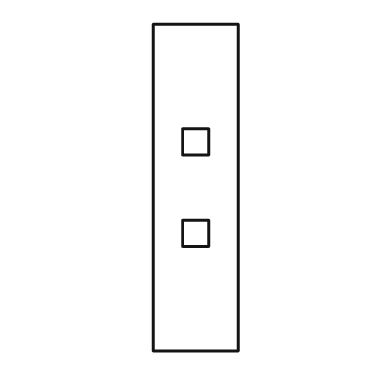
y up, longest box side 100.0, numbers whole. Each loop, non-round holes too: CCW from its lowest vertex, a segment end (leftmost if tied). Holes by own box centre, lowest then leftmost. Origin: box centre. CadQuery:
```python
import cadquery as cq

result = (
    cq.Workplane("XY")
    .moveTo(-13.0, -50.0)
    .lineTo(13.0, -50.0)
    .lineTo(13.0, 50.0)
    .lineTo(-13.0, 50.0)
    .close()
    .moveTo(-4.0, -18.0)
    .lineTo(4.0, -18.0)
    .lineTo(4.0, -10.0)
    .lineTo(-4.0, -10.0)
    .close()
    .moveTo(-4.0, 10.0)
    .lineTo(4.0, 10.0)
    .lineTo(4.0, 18.0)
    .lineTo(-4.0, 18.0)
    .close()
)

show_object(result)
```